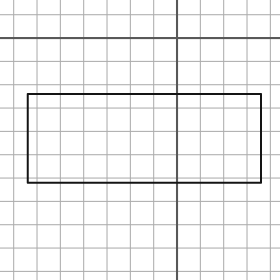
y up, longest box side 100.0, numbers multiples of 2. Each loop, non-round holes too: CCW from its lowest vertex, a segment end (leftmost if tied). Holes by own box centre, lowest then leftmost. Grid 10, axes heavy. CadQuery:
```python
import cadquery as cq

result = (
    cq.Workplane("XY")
    .moveTo(-64.0, -62.0)
    .lineTo(36.0, -62.0)
    .lineTo(36.0, -24.0)
    .lineTo(-64.0, -24.0)
    .close()
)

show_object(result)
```